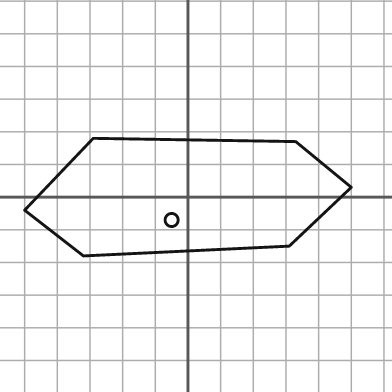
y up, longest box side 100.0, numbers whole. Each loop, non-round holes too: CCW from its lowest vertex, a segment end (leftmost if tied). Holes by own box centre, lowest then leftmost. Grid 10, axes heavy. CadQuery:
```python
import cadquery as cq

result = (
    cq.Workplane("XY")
    .moveTo(-32.0, -18.0)
    .lineTo(31.0, -15.0)
    .lineTo(50.0, 3.0)
    .lineTo(33.0, 17.0)
    .lineTo(-29.0, 18.0)
    .lineTo(-50.0, -4.0)
    .close()
    .moveTo(-5.0, -7.0)
    .circle(2.0)
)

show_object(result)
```